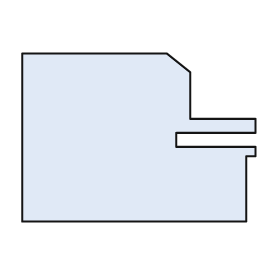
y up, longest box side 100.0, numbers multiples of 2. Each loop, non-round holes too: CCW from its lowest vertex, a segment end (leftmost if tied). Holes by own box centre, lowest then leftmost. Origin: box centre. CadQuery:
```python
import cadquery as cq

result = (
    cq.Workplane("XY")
    .moveTo(-50.0, -36.0)
    .lineTo(46.0, -36.0)
    .lineTo(46.0, -8.0)
    .lineTo(50.0, -8.0)
    .lineTo(50.0, -4.0)
    .lineTo(16.0, -4.0)
    .lineTo(16.0, 2.0)
    .lineTo(50.0, 2.0)
    .lineTo(50.0, 8.0)
    .lineTo(22.0, 8.0)
    .lineTo(22.0, 28.0)
    .lineTo(12.0, 36.0)
    .lineTo(-50.0, 36.0)
    .close()
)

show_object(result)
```